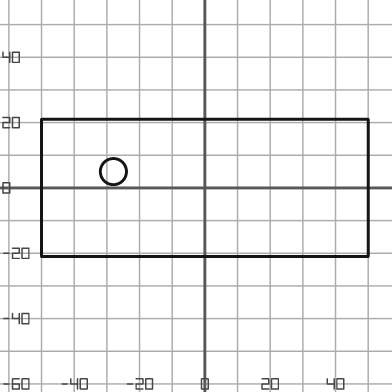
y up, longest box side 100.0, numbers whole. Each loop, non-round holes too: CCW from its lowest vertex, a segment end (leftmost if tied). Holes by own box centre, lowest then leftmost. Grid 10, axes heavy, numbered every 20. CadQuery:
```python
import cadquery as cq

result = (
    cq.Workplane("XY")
    .moveTo(-50.0, -21.0)
    .lineTo(50.0, -21.0)
    .lineTo(50.0, 21.0)
    .lineTo(-50.0, 21.0)
    .close()
    .moveTo(-28.0, 5.0)
    .circle(4.0)
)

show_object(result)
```